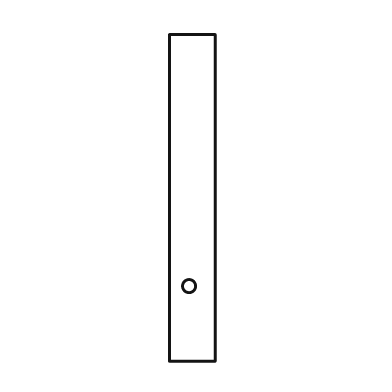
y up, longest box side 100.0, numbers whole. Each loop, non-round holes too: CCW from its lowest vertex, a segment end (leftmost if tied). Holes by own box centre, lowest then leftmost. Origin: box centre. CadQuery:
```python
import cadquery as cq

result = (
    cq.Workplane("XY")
    .moveTo(-7.0, -50.0)
    .lineTo(7.0, -50.0)
    .lineTo(7.0, 50.0)
    .lineTo(-7.0, 50.0)
    .close()
    .moveTo(-1.0, -27.0)
    .circle(2.0)
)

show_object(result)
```